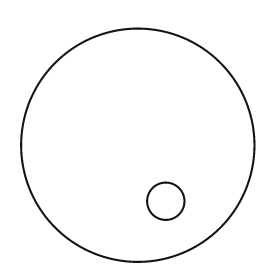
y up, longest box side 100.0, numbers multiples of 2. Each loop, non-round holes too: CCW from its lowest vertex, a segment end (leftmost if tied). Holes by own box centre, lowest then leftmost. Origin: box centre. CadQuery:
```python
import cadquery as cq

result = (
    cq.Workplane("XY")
    .moveTo(0.0, 0.0)
    .circle(50.0)
    .moveTo(12.0, -24.0)
    .circle(8.0)
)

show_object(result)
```